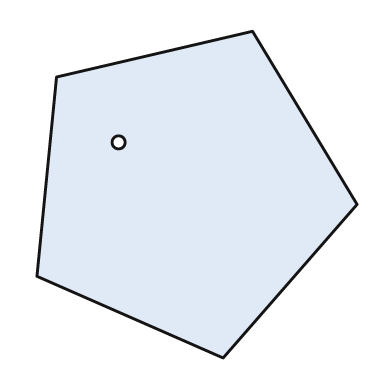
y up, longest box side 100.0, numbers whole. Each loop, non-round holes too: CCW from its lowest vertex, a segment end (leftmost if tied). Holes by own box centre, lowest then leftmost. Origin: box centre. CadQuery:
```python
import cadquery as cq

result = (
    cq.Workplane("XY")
    .moveTo(8.0, -50.0)
    .lineTo(49.0, -3.0)
    .lineTo(17.0, 50.0)
    .lineTo(-43.0, 36.0)
    .lineTo(-49.0, -25.0)
    .close()
    .moveTo(-24.0, 16.0)
    .circle(2.0)
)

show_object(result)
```